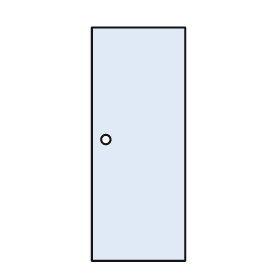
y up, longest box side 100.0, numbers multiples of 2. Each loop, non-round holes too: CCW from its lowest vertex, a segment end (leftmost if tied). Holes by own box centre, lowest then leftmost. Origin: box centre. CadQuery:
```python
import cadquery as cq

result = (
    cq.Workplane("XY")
    .moveTo(-20.0, -50.0)
    .lineTo(20.0, -50.0)
    .lineTo(20.0, 50.0)
    .lineTo(-20.0, 50.0)
    .close()
    .moveTo(-14.0, 2.0)
    .circle(2.0)
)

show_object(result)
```